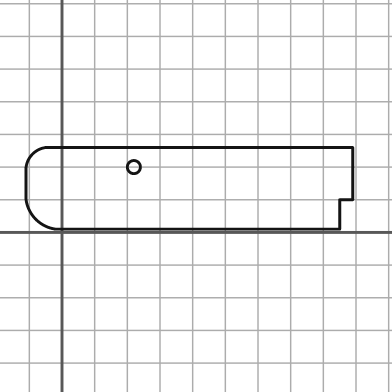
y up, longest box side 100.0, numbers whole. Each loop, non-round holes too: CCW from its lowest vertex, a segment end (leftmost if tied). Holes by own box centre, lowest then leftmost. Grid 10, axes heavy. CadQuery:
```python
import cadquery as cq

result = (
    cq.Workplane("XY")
    .moveTo(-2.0, 1.0)
    .lineTo(85.0, 1.0)
    .lineTo(85.0, 10.0)
    .lineTo(89.0, 10.0)
    .lineTo(89.0, 26.0)
    .lineTo(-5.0, 26.0)
    .threePointArc((-9.0, 24.0), (-11.0, 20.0))
    .lineTo(-11.0, 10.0)
    .threePointArc((-8.0, 4.0), (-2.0, 1.0))
    .close()
    .moveTo(22.0, 20.0)
    .circle(2.0)
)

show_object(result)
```